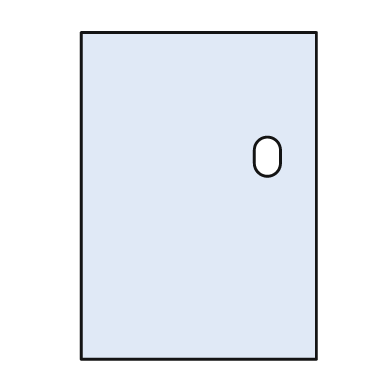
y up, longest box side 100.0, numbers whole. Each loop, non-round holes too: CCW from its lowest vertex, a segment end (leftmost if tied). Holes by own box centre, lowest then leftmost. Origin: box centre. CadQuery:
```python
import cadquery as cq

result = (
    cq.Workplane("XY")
    .moveTo(-36.0, -50.0)
    .lineTo(36.0, -50.0)
    .lineTo(36.0, 50.0)
    .lineTo(-36.0, 50.0)
    .close()
    .moveTo(17.0, 10.0)
    .threePointArc((21.0, 6.0), (25.0, 10.0))
    .lineTo(25.0, 14.0)
    .threePointArc((21.0, 18.0), (17.0, 14.0))
    .close()
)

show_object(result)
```